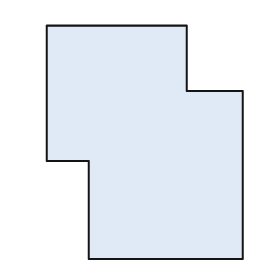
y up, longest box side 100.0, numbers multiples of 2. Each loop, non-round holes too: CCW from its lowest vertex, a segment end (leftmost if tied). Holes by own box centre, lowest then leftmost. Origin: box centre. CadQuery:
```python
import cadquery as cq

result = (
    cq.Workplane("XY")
    .moveTo(-24.0, -50.0)
    .lineTo(42.0, -50.0)
    .lineTo(42.0, 22.0)
    .lineTo(18.0, 22.0)
    .lineTo(18.0, 50.0)
    .lineTo(-42.0, 50.0)
    .lineTo(-42.0, -8.0)
    .lineTo(-24.0, -8.0)
    .close()
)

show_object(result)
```